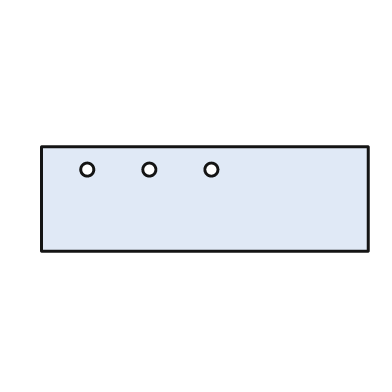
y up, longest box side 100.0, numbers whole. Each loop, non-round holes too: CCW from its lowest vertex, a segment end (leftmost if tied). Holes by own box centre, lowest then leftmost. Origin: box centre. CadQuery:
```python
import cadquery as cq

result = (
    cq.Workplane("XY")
    .moveTo(-50.0, -16.0)
    .lineTo(50.0, -16.0)
    .lineTo(50.0, 16.0)
    .lineTo(-50.0, 16.0)
    .close()
    .moveTo(-36.0, 9.0)
    .circle(2.0)
    .moveTo(-17.0, 9.0)
    .circle(2.0)
    .moveTo(2.0, 9.0)
    .circle(2.0)
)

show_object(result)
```